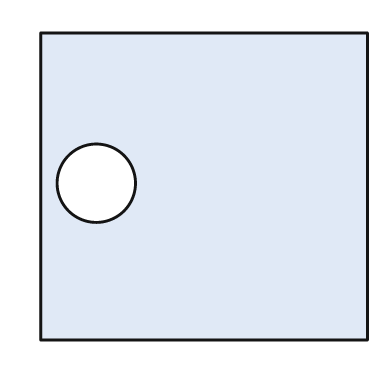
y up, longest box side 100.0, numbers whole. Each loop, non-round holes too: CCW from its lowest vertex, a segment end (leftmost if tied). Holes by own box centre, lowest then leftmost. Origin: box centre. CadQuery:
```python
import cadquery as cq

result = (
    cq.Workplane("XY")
    .moveTo(-50.0, -47.0)
    .lineTo(50.0, -47.0)
    .lineTo(50.0, 47.0)
    .lineTo(-50.0, 47.0)
    .close()
    .moveTo(-33.0, 1.0)
    .circle(12.0)
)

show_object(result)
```